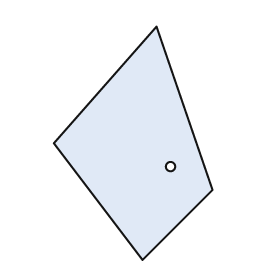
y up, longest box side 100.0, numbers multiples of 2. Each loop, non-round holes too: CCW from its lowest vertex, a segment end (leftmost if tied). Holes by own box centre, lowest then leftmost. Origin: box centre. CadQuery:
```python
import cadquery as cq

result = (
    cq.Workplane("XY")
    .moveTo(4.0, -50.0)
    .lineTo(34.0, -20.0)
    .lineTo(10.0, 50.0)
    .lineTo(-34.0, 0.0)
    .close()
    .moveTo(16.0, -10.0)
    .circle(2.0)
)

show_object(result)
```